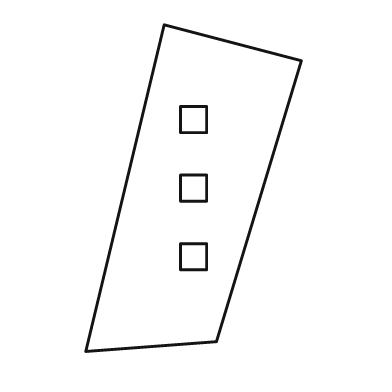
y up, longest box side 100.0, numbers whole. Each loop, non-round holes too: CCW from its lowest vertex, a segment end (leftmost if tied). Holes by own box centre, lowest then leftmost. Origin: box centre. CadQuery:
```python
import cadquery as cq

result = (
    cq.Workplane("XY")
    .moveTo(-33.0, -50.0)
    .lineTo(7.0, -47.0)
    .lineTo(33.0, 39.0)
    .lineTo(-9.0, 50.0)
    .close()
    .moveTo(-4.0, -25.0)
    .lineTo(4.0, -25.0)
    .lineTo(4.0, -17.0)
    .lineTo(-4.0, -17.0)
    .close()
    .moveTo(-4.0, -4.0)
    .lineTo(4.0, -4.0)
    .lineTo(4.0, 4.0)
    .lineTo(-4.0, 4.0)
    .close()
    .moveTo(-4.0, 17.0)
    .lineTo(4.0, 17.0)
    .lineTo(4.0, 25.0)
    .lineTo(-4.0, 25.0)
    .close()
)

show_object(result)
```